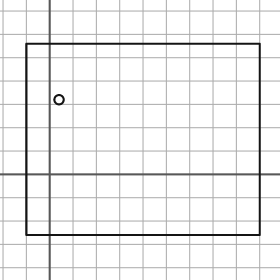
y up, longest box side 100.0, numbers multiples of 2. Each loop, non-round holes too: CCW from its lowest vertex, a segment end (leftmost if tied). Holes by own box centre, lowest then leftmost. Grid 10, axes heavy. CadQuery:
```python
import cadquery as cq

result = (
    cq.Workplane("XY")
    .moveTo(-10.0, -26.0)
    .lineTo(90.0, -26.0)
    .lineTo(90.0, 56.0)
    .lineTo(-10.0, 56.0)
    .close()
    .moveTo(4.0, 32.0)
    .circle(2.0)
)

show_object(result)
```